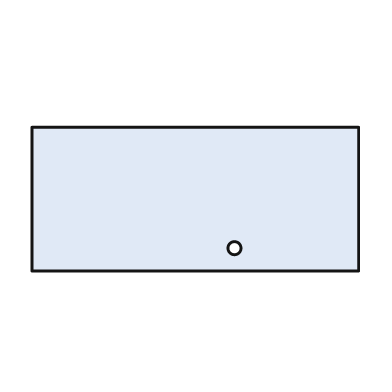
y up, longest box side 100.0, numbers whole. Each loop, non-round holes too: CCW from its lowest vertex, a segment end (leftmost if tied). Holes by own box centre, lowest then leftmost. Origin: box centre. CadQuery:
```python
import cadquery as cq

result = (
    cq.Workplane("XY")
    .moveTo(-50.0, -22.0)
    .lineTo(50.0, -22.0)
    .lineTo(50.0, 22.0)
    .lineTo(-50.0, 22.0)
    .close()
    .moveTo(12.0, -15.0)
    .circle(2.0)
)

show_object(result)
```